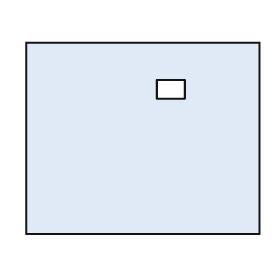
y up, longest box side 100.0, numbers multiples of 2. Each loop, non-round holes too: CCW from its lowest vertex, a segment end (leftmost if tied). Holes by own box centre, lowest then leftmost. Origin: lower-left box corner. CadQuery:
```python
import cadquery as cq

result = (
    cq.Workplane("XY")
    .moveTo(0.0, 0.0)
    .lineTo(100.0, 0.0)
    .lineTo(100.0, 82.0)
    .lineTo(0.0, 82.0)
    .close()
    .moveTo(56.0, 58.0)
    .lineTo(68.0, 58.0)
    .lineTo(68.0, 66.0)
    .lineTo(56.0, 66.0)
    .close()
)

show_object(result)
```